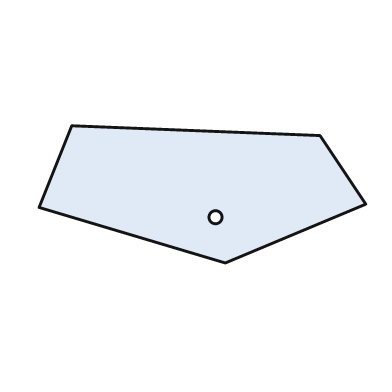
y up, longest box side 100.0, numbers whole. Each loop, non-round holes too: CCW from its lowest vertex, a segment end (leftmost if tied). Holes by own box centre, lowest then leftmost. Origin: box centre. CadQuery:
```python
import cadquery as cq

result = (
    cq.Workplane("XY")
    .moveTo(7.0, -21.0)
    .lineTo(50.0, -3.0)
    .lineTo(36.0, 18.0)
    .lineTo(-40.0, 21.0)
    .lineTo(-50.0, -4.0)
    .close()
    .moveTo(4.0, -7.0)
    .circle(2.0)
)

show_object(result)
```